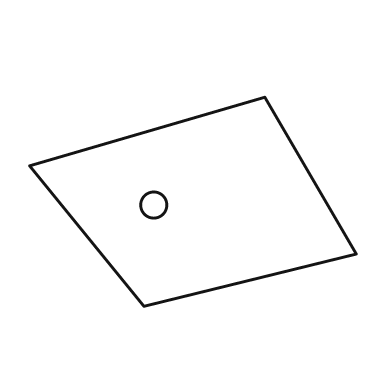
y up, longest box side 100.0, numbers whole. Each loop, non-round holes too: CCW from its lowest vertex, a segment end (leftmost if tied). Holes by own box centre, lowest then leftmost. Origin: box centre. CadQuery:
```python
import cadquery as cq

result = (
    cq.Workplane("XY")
    .moveTo(-15.0, -32.0)
    .lineTo(50.0, -16.0)
    .lineTo(22.0, 32.0)
    .lineTo(-50.0, 11.0)
    .close()
    .moveTo(-12.0, -1.0)
    .circle(4.0)
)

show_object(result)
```